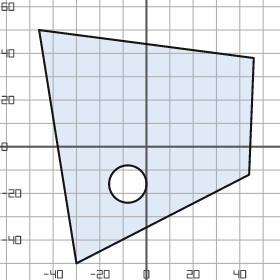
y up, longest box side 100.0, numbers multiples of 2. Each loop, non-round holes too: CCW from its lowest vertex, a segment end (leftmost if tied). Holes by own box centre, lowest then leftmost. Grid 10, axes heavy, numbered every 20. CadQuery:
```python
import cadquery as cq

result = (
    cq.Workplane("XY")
    .moveTo(-30.0, -50.0)
    .lineTo(44.0, -12.0)
    .lineTo(46.0, 38.0)
    .lineTo(-46.0, 50.0)
    .close()
    .moveTo(-8.0, -16.0)
    .circle(8.0)
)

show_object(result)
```